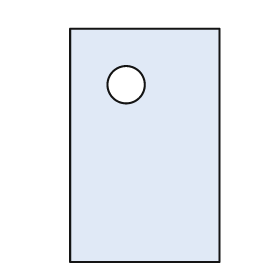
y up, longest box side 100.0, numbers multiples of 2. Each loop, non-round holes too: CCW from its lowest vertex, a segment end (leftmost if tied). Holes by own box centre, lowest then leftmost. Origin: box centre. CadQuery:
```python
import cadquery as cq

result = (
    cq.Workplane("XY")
    .moveTo(-32.0, -50.0)
    .lineTo(32.0, -50.0)
    .lineTo(32.0, 50.0)
    .lineTo(-32.0, 50.0)
    .close()
    .moveTo(-8.0, 26.0)
    .circle(8.0)
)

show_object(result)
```